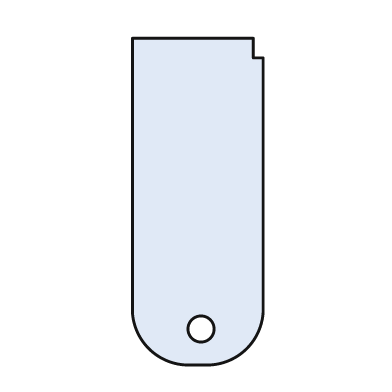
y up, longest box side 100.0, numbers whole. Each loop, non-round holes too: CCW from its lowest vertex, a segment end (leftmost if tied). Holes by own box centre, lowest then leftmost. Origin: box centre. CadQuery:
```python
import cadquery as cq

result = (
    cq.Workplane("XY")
    .moveTo(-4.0, -50.0)
    .lineTo(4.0, -50.0)
    .threePointArc((15.0, -45.0), (20.0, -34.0))
    .lineTo(20.0, 44.0)
    .lineTo(17.0, 44.0)
    .lineTo(17.0, 50.0)
    .lineTo(-20.0, 50.0)
    .lineTo(-20.0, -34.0)
    .threePointArc((-15.0, -45.0), (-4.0, -50.0))
    .close()
    .moveTo(1.0, -39.0)
    .circle(4.0)
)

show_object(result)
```